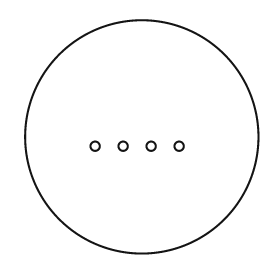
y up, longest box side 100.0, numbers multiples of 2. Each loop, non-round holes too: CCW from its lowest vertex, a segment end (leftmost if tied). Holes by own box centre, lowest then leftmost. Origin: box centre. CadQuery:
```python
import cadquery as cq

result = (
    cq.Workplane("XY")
    .moveTo(0.0, 0.0)
    .circle(50.0)
    .moveTo(-20.0, -4.0)
    .circle(2.0)
    .moveTo(-8.0, -4.0)
    .circle(2.0)
    .moveTo(4.0, -4.0)
    .circle(2.0)
    .moveTo(16.0, -4.0)
    .circle(2.0)
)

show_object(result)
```